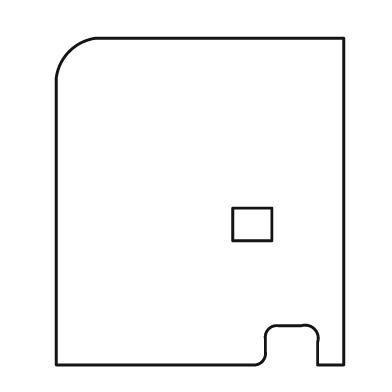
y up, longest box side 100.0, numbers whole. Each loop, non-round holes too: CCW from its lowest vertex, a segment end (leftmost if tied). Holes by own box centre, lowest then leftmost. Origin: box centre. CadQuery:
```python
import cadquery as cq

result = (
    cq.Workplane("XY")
    .moveTo(-44.0, -50.0)
    .lineTo(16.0, -50.0)
    .threePointArc((19.0, -49.0), (20.0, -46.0))
    .lineTo(20.0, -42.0)
    .threePointArc((21.0, -39.0), (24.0, -38.0))
    .lineTo(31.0, -38.0)
    .threePointArc((35.0, -39.0), (36.0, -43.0))
    .lineTo(36.0, -50.0)
    .lineTo(44.0, -50.0)
    .lineTo(44.0, 50.0)
    .lineTo(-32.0, 50.0)
    .threePointArc((-40.0, 46.0), (-44.0, 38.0))
    .close()
    .moveTo(10.0, -12.0)
    .lineTo(22.0, -12.0)
    .lineTo(22.0, -2.0)
    .lineTo(10.0, -2.0)
    .close()
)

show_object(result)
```